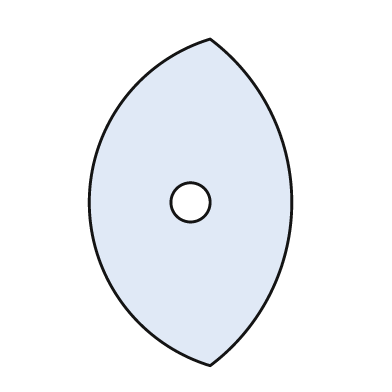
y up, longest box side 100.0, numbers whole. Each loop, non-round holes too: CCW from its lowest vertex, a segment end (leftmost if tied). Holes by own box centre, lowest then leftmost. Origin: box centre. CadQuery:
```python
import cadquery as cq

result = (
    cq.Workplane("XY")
    .moveTo(6.0, -50.0)
    .threePointArc((31.0, 0.0), (6.0, 50.0))
    .threePointArc((-31.0, 0.0), (6.0, -50.0))
    .close()
    .moveTo(0.0, 0.0)
    .circle(6.0)
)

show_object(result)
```